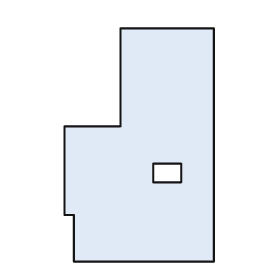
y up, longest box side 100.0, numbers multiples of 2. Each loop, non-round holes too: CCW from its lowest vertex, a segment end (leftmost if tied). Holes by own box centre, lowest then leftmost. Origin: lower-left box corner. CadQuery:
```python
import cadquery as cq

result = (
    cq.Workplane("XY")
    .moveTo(4.0, 0.0)
    .lineTo(64.0, 0.0)
    .lineTo(64.0, 100.0)
    .lineTo(24.0, 100.0)
    .lineTo(24.0, 58.0)
    .lineTo(0.0, 58.0)
    .lineTo(0.0, 20.0)
    .lineTo(4.0, 20.0)
    .close()
    .moveTo(38.0, 34.0)
    .lineTo(50.0, 34.0)
    .lineTo(50.0, 42.0)
    .lineTo(38.0, 42.0)
    .close()
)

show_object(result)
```